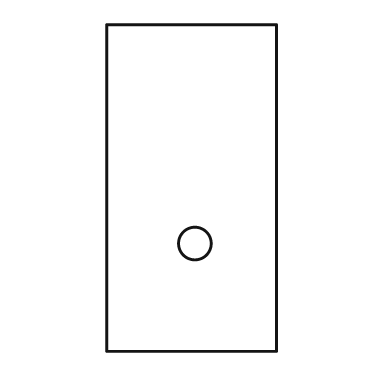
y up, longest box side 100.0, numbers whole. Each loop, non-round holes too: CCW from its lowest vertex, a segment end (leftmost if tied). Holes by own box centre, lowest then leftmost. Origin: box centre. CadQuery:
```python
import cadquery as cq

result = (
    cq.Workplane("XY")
    .moveTo(-26.0, -50.0)
    .lineTo(26.0, -50.0)
    .lineTo(26.0, 50.0)
    .lineTo(-26.0, 50.0)
    .close()
    .moveTo(1.0, -17.0)
    .circle(5.0)
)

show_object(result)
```